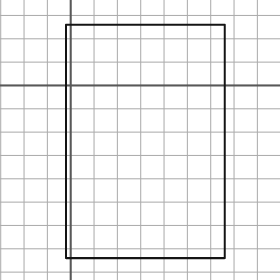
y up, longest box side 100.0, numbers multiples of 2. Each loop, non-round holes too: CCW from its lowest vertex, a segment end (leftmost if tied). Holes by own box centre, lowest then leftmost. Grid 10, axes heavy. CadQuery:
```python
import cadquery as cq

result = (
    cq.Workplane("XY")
    .moveTo(-2.0, -74.0)
    .lineTo(66.0, -74.0)
    .lineTo(66.0, 26.0)
    .lineTo(-2.0, 26.0)
    .close()
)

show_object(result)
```